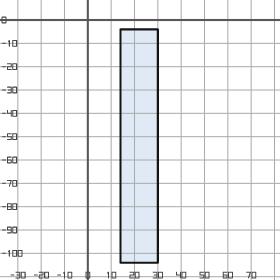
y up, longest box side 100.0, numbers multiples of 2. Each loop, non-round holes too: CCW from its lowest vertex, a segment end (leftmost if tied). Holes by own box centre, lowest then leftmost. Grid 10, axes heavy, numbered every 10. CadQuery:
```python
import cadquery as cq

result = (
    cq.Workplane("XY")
    .moveTo(14.0, -104.0)
    .lineTo(30.0, -104.0)
    .lineTo(30.0, -4.0)
    .lineTo(14.0, -4.0)
    .close()
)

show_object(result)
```